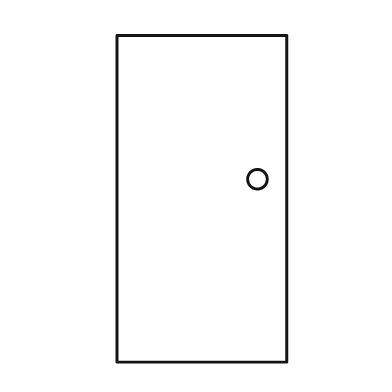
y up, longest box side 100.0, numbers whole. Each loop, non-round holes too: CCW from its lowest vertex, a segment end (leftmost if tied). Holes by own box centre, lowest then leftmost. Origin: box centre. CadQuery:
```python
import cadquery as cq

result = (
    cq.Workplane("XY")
    .moveTo(-26.0, -50.0)
    .lineTo(26.0, -50.0)
    .lineTo(26.0, 50.0)
    .lineTo(-26.0, 50.0)
    .close()
    .moveTo(17.0, 6.0)
    .circle(3.0)
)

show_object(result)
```